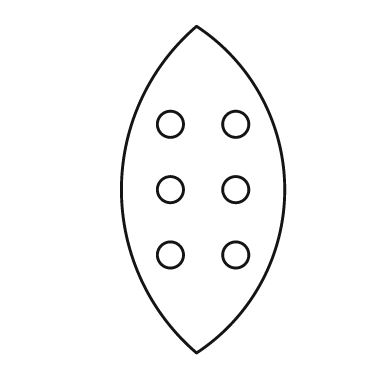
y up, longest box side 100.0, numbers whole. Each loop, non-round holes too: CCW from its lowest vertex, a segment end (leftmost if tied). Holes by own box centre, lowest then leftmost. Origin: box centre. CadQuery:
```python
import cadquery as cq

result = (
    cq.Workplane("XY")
    .moveTo(-2.0, -50.0)
    .threePointArc((25.0, 0.0), (-2.0, 50.0))
    .threePointArc((-25.0, 0.0), (-2.0, -50.0))
    .close()
    .moveTo(-10.0, -20.0)
    .circle(4.0)
    .moveTo(10.0, -20.0)
    .circle(4.0)
    .moveTo(-10.0, 0.0)
    .circle(4.0)
    .moveTo(10.0, 0.0)
    .circle(4.0)
    .moveTo(-10.0, 20.0)
    .circle(4.0)
    .moveTo(10.0, 20.0)
    .circle(4.0)
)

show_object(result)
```